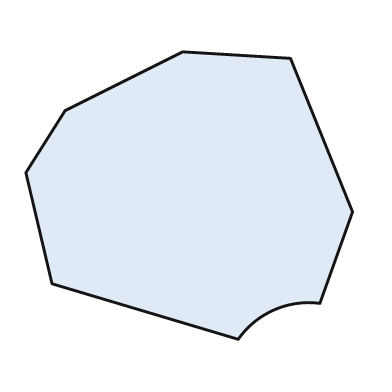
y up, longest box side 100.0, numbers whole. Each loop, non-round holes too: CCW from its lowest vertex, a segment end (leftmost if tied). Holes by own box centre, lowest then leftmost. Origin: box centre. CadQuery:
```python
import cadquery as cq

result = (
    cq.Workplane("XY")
    .moveTo(15.0, -44.0)
    .threePointArc((26.0, -35.0), (40.0, -33.0))
    .lineTo(50.0, -5.0)
    .lineTo(31.0, 42.0)
    .lineTo(-2.0, 44.0)
    .lineTo(-38.0, 26.0)
    .lineTo(-50.0, 7.0)
    .lineTo(-42.0, -27.0)
    .close()
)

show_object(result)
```